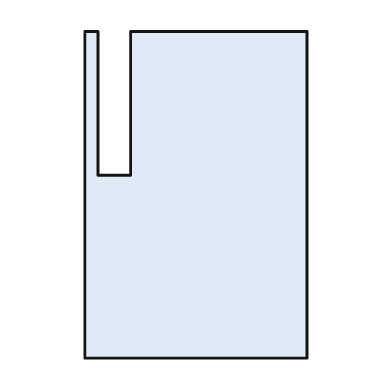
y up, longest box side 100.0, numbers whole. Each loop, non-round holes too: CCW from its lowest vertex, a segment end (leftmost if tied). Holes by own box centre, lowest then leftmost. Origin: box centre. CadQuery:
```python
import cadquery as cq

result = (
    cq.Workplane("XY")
    .moveTo(-34.0, -50.0)
    .lineTo(34.0, -50.0)
    .lineTo(34.0, 50.0)
    .lineTo(-20.0, 50.0)
    .lineTo(-20.0, 6.0)
    .lineTo(-30.0, 6.0)
    .lineTo(-30.0, 50.0)
    .lineTo(-34.0, 50.0)
    .close()
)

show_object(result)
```